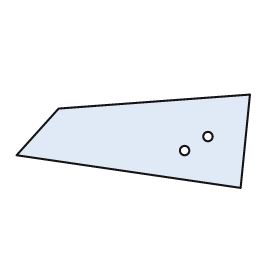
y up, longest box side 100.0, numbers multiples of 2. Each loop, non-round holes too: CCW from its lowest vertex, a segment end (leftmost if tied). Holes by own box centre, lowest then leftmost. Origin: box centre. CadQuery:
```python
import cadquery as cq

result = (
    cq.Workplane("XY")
    .moveTo(46.0, -20.0)
    .lineTo(50.0, 20.0)
    .lineTo(-32.0, 14.0)
    .lineTo(-50.0, -6.0)
    .close()
    .moveTo(22.0, -4.0)
    .circle(2.0)
    .moveTo(32.0, 2.0)
    .circle(2.0)
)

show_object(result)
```